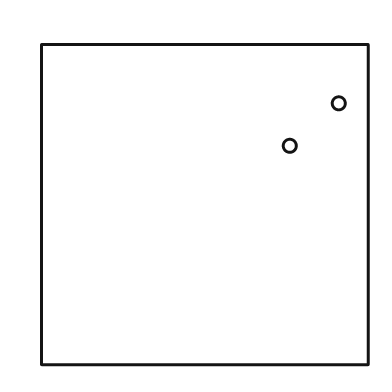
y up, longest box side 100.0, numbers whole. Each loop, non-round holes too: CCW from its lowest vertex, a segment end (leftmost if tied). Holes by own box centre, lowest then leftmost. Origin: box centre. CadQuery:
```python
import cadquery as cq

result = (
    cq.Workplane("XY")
    .moveTo(-50.0, -49.0)
    .lineTo(50.0, -49.0)
    .lineTo(50.0, 49.0)
    .lineTo(-50.0, 49.0)
    .close()
    .moveTo(26.0, 18.0)
    .circle(2.0)
    .moveTo(41.0, 31.0)
    .circle(2.0)
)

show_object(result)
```